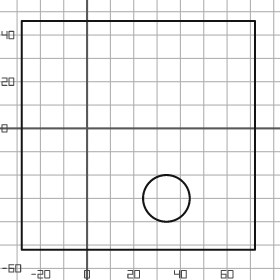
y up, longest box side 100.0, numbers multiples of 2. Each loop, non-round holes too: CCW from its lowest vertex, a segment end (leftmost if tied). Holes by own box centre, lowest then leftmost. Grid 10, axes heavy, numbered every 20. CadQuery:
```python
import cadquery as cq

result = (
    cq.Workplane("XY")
    .moveTo(-28.0, -52.0)
    .lineTo(72.0, -52.0)
    .lineTo(72.0, 46.0)
    .lineTo(-28.0, 46.0)
    .close()
    .moveTo(34.0, -30.0)
    .circle(10.0)
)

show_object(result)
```